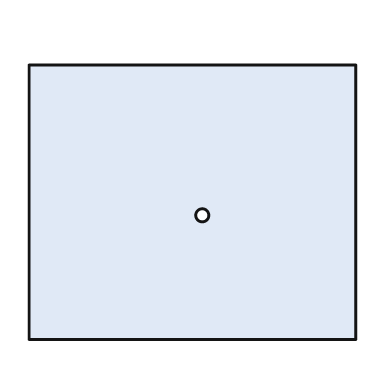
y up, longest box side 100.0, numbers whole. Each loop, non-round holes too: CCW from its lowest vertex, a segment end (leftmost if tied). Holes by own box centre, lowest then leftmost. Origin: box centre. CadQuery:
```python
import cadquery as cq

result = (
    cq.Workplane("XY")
    .moveTo(-50.0, -42.0)
    .lineTo(50.0, -42.0)
    .lineTo(50.0, 42.0)
    .lineTo(-50.0, 42.0)
    .close()
    .moveTo(3.0, -4.0)
    .circle(2.0)
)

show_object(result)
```